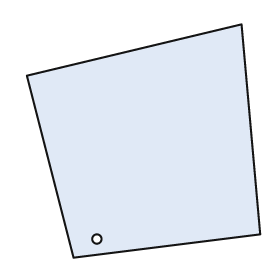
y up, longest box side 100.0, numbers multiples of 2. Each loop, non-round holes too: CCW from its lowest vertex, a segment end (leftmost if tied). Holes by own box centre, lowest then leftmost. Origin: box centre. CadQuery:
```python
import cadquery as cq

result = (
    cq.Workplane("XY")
    .moveTo(-30.0, -50.0)
    .lineTo(50.0, -40.0)
    .lineTo(42.0, 50.0)
    .lineTo(-50.0, 28.0)
    .close()
    .moveTo(-20.0, -42.0)
    .circle(2.0)
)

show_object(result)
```